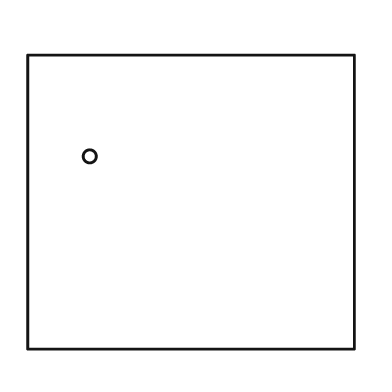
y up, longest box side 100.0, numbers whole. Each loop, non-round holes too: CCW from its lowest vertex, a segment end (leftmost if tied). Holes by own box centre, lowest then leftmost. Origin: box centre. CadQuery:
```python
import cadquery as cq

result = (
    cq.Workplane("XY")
    .moveTo(-50.0, -45.0)
    .lineTo(50.0, -45.0)
    .lineTo(50.0, 45.0)
    .lineTo(-50.0, 45.0)
    .close()
    .moveTo(-31.0, 14.0)
    .circle(2.0)
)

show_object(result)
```